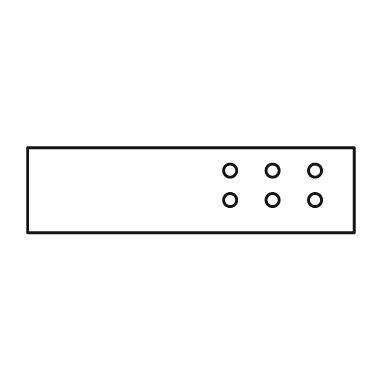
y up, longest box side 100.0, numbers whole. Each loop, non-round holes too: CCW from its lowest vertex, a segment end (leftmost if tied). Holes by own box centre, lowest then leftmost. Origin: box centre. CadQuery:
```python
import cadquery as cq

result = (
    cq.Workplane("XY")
    .moveTo(-50.0, -13.0)
    .lineTo(50.0, -13.0)
    .lineTo(50.0, 13.0)
    .lineTo(-50.0, 13.0)
    .close()
    .moveTo(12.0, -3.0)
    .circle(2.0)
    .moveTo(25.0, -3.0)
    .circle(2.0)
    .moveTo(38.0, -3.0)
    .circle(2.0)
    .moveTo(12.0, 6.0)
    .circle(2.0)
    .moveTo(25.0, 6.0)
    .circle(2.0)
    .moveTo(38.0, 6.0)
    .circle(2.0)
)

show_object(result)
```